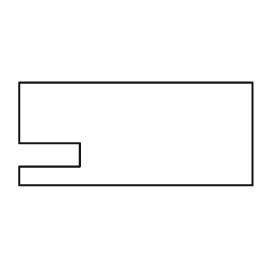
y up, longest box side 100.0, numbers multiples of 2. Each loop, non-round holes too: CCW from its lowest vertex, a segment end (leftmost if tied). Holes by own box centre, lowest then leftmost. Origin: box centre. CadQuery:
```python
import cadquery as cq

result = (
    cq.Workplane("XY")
    .moveTo(-50.0, -22.0)
    .lineTo(50.0, -22.0)
    .lineTo(50.0, 22.0)
    .lineTo(-50.0, 22.0)
    .lineTo(-50.0, -4.0)
    .lineTo(-24.0, -4.0)
    .lineTo(-24.0, -14.0)
    .lineTo(-50.0, -14.0)
    .close()
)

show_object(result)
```